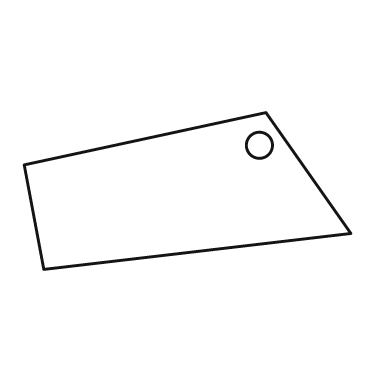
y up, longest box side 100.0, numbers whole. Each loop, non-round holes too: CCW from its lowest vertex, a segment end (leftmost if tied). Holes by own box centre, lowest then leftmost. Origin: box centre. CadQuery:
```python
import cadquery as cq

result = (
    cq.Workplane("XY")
    .moveTo(-44.0, -24.0)
    .lineTo(50.0, -13.0)
    .lineTo(24.0, 24.0)
    .lineTo(-50.0, 8.0)
    .close()
    .moveTo(22.0, 14.0)
    .circle(4.0)
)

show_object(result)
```